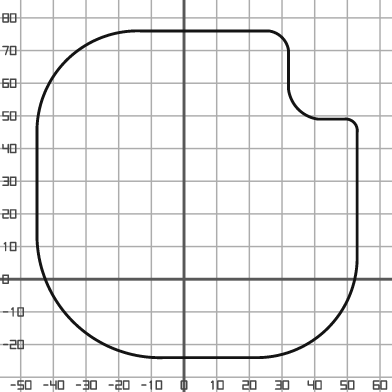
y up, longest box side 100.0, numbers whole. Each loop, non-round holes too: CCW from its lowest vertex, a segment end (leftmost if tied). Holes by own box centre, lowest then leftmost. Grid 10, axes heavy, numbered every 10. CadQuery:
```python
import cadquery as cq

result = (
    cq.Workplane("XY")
    .moveTo(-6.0, -24.0)
    .lineTo(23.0, -24.0)
    .threePointArc((44.0, -15.0), (53.0, 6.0))
    .lineTo(53.0, 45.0)
    .threePointArc((52.0, 48.0), (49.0, 49.0))
    .lineTo(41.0, 49.0)
    .threePointArc((35.0, 52.0), (32.0, 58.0))
    .lineTo(32.0, 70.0)
    .threePointArc((30.0, 74.0), (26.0, 76.0))
    .lineTo(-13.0, 76.0)
    .threePointArc((-36.0, 67.0), (-45.0, 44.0))
    .lineTo(-45.0, 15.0)
    .threePointArc((-34.0, -13.0), (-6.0, -24.0))
    .close()
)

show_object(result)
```